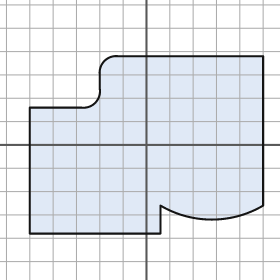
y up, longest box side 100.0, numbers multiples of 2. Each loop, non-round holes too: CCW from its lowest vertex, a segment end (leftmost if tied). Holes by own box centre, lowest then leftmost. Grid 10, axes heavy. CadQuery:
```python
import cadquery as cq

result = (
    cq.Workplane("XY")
    .moveTo(-50.0, -38.0)
    .lineTo(6.0, -38.0)
    .lineTo(6.0, -26.0)
    .threePointArc((28.0, -32.0), (50.0, -26.0))
    .lineTo(50.0, 38.0)
    .lineTo(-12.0, 38.0)
    .threePointArc((-18.0, 36.0), (-20.0, 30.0))
    .lineTo(-20.0, 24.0)
    .threePointArc((-22.0, 18.0), (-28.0, 16.0))
    .lineTo(-50.0, 16.0)
    .close()
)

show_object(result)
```